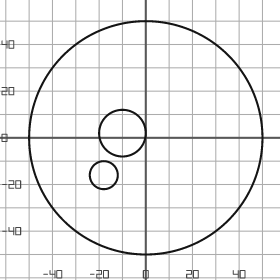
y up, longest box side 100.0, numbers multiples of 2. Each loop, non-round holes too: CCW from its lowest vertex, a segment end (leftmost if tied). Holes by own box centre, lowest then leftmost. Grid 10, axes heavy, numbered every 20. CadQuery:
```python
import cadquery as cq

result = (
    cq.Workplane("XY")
    .moveTo(0.0, 0.0)
    .circle(50.0)
    .moveTo(-18.0, -16.0)
    .circle(6.0)
    .moveTo(-10.0, 2.0)
    .circle(10.0)
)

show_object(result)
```